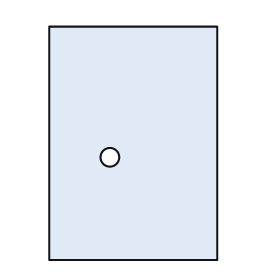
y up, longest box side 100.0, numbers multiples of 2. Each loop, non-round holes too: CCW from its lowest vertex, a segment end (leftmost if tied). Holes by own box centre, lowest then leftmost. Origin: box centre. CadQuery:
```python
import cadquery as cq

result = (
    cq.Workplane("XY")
    .moveTo(-36.0, -50.0)
    .lineTo(36.0, -50.0)
    .lineTo(36.0, 50.0)
    .lineTo(-36.0, 50.0)
    .close()
    .moveTo(-10.0, -6.0)
    .circle(4.0)
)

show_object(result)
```